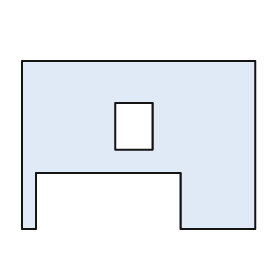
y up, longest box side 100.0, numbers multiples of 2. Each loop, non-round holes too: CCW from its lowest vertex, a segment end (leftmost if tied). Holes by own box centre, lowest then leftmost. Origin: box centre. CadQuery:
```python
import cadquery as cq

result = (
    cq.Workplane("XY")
    .moveTo(-50.0, -36.0)
    .lineTo(-44.0, -36.0)
    .lineTo(-44.0, -12.0)
    .lineTo(18.0, -12.0)
    .lineTo(18.0, -36.0)
    .lineTo(50.0, -36.0)
    .lineTo(50.0, 36.0)
    .lineTo(-50.0, 36.0)
    .close()
    .moveTo(-10.0, -2.0)
    .lineTo(6.0, -2.0)
    .lineTo(6.0, 18.0)
    .lineTo(-10.0, 18.0)
    .close()
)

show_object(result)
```